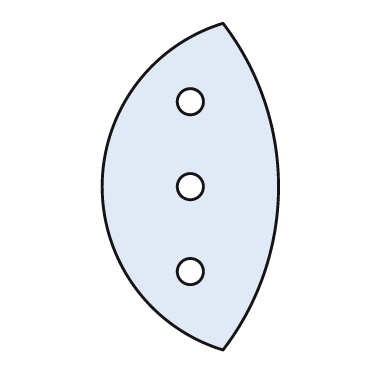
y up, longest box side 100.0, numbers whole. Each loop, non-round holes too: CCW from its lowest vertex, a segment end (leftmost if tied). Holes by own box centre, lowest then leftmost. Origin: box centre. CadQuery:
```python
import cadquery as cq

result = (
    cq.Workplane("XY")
    .moveTo(10.0, -50.0)
    .threePointArc((27.0, 0.0), (10.0, 50.0))
    .threePointArc((-27.0, 0.0), (10.0, -50.0))
    .close()
    .moveTo(0.0, -26.0)
    .circle(4.0)
    .moveTo(0.0, 0.0)
    .circle(4.0)
    .moveTo(0.0, 26.0)
    .circle(4.0)
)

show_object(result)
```